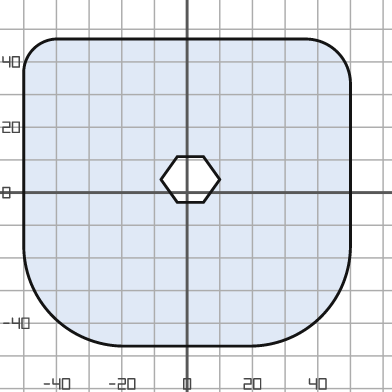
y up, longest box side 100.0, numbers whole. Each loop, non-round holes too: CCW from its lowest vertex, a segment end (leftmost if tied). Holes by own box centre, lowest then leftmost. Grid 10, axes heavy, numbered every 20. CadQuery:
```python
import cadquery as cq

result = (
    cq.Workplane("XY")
    .moveTo(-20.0, -47.0)
    .lineTo(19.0, -47.0)
    .threePointArc((41.0, -38.0), (50.0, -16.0))
    .lineTo(50.0, 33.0)
    .threePointArc((46.0, 43.0), (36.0, 47.0))
    .lineTo(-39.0, 47.0)
    .threePointArc((-47.0, 44.0), (-50.0, 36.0))
    .lineTo(-50.0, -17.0)
    .threePointArc((-41.0, -38.0), (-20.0, -47.0))
    .close()
    .moveTo(-3.0, -3.0)
    .lineTo(5.0, -3.0)
    .lineTo(10.0, 4.0)
    .lineTo(5.0, 11.0)
    .lineTo(-3.0, 11.0)
    .lineTo(-8.0, 4.0)
    .close()
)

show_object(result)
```